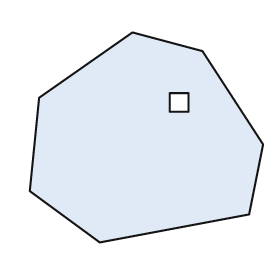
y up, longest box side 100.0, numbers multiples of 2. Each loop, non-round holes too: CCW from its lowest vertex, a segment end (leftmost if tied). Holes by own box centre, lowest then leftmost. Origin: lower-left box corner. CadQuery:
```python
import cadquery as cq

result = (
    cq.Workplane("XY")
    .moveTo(30.0, 0.0)
    .lineTo(94.0, 12.0)
    .lineTo(100.0, 42.0)
    .lineTo(74.0, 82.0)
    .lineTo(44.0, 90.0)
    .lineTo(4.0, 62.0)
    .lineTo(0.0, 22.0)
    .close()
    .moveTo(60.0, 56.0)
    .lineTo(68.0, 56.0)
    .lineTo(68.0, 64.0)
    .lineTo(60.0, 64.0)
    .close()
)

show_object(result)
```